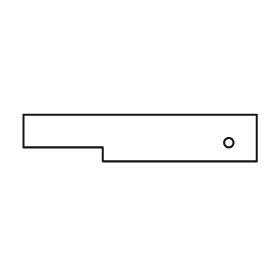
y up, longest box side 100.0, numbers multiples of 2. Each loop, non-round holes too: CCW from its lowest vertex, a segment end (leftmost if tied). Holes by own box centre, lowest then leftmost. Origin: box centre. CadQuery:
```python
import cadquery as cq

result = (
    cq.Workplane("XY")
    .moveTo(-16.0, -10.0)
    .lineTo(50.0, -10.0)
    .lineTo(50.0, 10.0)
    .lineTo(-50.0, 10.0)
    .lineTo(-50.0, -4.0)
    .lineTo(-16.0, -4.0)
    .close()
    .moveTo(38.0, -2.0)
    .circle(2.0)
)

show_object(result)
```